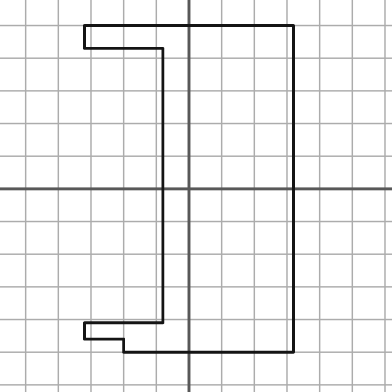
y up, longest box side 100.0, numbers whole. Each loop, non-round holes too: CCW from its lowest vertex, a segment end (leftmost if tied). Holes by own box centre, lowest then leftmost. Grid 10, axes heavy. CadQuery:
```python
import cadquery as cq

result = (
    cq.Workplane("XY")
    .moveTo(-20.0, -50.0)
    .lineTo(32.0, -50.0)
    .lineTo(32.0, 50.0)
    .lineTo(-32.0, 50.0)
    .lineTo(-32.0, 43.0)
    .lineTo(-8.0, 43.0)
    .lineTo(-8.0, -41.0)
    .lineTo(-32.0, -41.0)
    .lineTo(-32.0, -46.0)
    .lineTo(-20.0, -46.0)
    .close()
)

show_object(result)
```